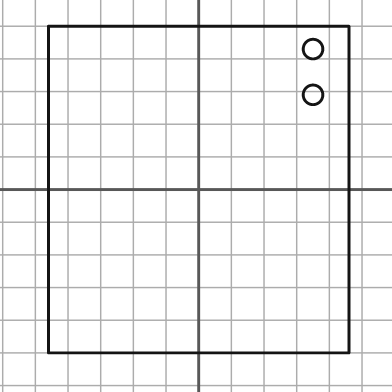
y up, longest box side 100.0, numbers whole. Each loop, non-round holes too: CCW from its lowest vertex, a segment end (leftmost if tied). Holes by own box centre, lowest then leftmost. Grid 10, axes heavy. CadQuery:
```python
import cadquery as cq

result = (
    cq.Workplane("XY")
    .moveTo(-46.0, -50.0)
    .lineTo(46.0, -50.0)
    .lineTo(46.0, 50.0)
    .lineTo(-46.0, 50.0)
    .close()
    .moveTo(35.0, 29.0)
    .circle(3.0)
    .moveTo(35.0, 43.0)
    .circle(3.0)
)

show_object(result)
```